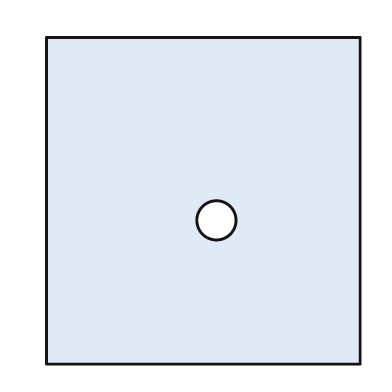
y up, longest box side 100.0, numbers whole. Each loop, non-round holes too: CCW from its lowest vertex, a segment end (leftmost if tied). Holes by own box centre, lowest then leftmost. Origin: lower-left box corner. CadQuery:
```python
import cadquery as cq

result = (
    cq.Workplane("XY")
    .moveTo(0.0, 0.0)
    .lineTo(96.0, 0.0)
    .lineTo(96.0, 100.0)
    .lineTo(0.0, 100.0)
    .close()
    .moveTo(52.0, 44.0)
    .circle(6.0)
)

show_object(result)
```